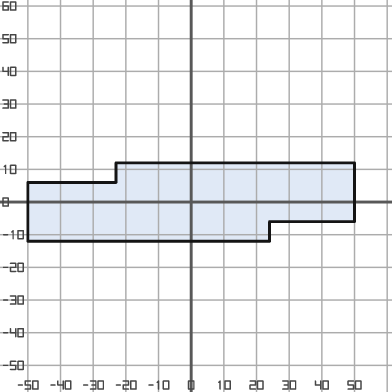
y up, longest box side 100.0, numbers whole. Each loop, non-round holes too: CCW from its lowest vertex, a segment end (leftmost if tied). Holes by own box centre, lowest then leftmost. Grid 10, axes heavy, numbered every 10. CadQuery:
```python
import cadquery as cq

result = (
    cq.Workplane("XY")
    .moveTo(-50.0, -12.0)
    .lineTo(24.0, -12.0)
    .lineTo(24.0, -6.0)
    .lineTo(50.0, -6.0)
    .lineTo(50.0, 12.0)
    .lineTo(-23.0, 12.0)
    .lineTo(-23.0, 6.0)
    .lineTo(-50.0, 6.0)
    .close()
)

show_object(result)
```